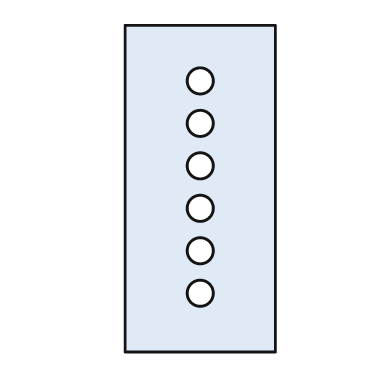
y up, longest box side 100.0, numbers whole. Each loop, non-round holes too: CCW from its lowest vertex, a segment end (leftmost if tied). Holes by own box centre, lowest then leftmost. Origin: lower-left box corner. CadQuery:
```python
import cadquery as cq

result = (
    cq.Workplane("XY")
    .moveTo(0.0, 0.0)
    .lineTo(46.0, 0.0)
    .lineTo(46.0, 100.0)
    .lineTo(0.0, 100.0)
    .close()
    .moveTo(23.0, 18.0)
    .circle(4.0)
    .moveTo(23.0, 31.0)
    .circle(4.0)
    .moveTo(23.0, 44.0)
    .circle(4.0)
    .moveTo(23.0, 57.0)
    .circle(4.0)
    .moveTo(23.0, 70.0)
    .circle(4.0)
    .moveTo(23.0, 83.0)
    .circle(4.0)
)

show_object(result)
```